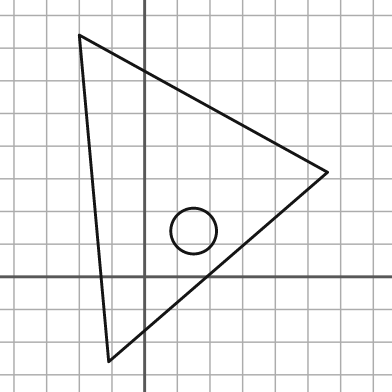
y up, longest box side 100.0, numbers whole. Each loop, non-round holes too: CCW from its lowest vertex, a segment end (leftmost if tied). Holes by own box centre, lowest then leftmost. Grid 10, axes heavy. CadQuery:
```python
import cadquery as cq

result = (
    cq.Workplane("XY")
    .moveTo(-11.0, -26.0)
    .lineTo(56.0, 32.0)
    .lineTo(-20.0, 74.0)
    .close()
    .moveTo(15.0, 14.0)
    .circle(7.0)
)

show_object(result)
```